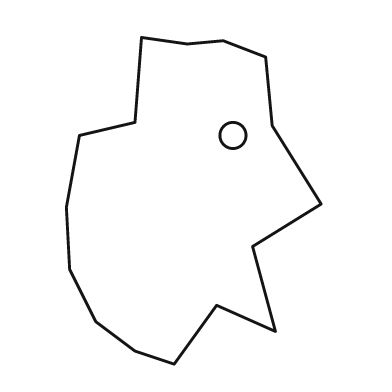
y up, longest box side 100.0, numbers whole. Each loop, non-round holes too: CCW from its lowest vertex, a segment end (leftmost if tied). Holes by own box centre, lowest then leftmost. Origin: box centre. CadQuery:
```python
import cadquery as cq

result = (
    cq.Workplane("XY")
    .moveTo(-6.0, -50.0)
    .lineTo(7.0, -32.0)
    .lineTo(25.0, -40.0)
    .lineTo(18.0, -14.0)
    .lineTo(39.0, -1.0)
    .lineTo(24.0, 23.0)
    .lineTo(22.0, 44.0)
    .lineTo(9.0, 49.0)
    .lineTo(-2.0, 48.0)
    .lineTo(-16.0, 50.0)
    .lineTo(-18.0, 24.0)
    .lineTo(-35.0, 20.0)
    .lineTo(-39.0, -2.0)
    .lineTo(-38.0, -21.0)
    .lineTo(-30.0, -37.0)
    .lineTo(-18.0, -46.0)
    .close()
    .moveTo(12.0, 20.0)
    .circle(4.0)
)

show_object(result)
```